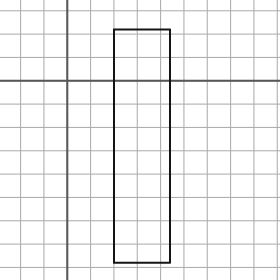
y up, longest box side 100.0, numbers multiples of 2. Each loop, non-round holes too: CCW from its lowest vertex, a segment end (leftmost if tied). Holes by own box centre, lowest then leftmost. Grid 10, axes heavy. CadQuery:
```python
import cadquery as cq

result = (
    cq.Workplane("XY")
    .moveTo(20.0, -78.0)
    .lineTo(44.0, -78.0)
    .lineTo(44.0, 22.0)
    .lineTo(20.0, 22.0)
    .close()
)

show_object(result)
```